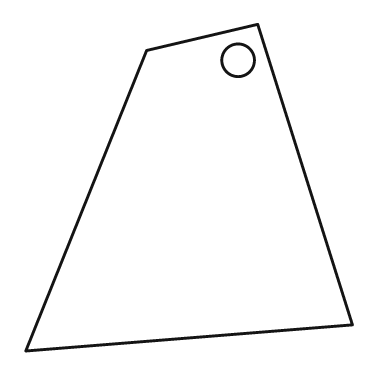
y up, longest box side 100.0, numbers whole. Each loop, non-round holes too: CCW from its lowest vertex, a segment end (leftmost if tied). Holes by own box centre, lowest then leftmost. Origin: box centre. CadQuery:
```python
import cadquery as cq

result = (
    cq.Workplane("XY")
    .moveTo(-50.0, -50.0)
    .lineTo(50.0, -42.0)
    .lineTo(21.0, 50.0)
    .lineTo(-13.0, 42.0)
    .close()
    .moveTo(15.0, 39.0)
    .circle(5.0)
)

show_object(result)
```